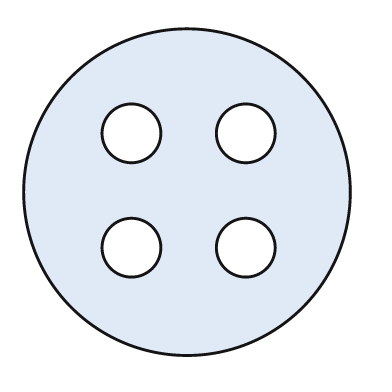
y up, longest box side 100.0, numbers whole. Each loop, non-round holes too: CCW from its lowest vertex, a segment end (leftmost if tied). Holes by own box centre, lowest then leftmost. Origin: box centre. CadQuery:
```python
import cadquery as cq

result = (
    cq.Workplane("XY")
    .moveTo(0.0, 0.0)
    .circle(50.0)
    .moveTo(-17.0, -17.0)
    .circle(9.0)
    .moveTo(18.0, -17.0)
    .circle(9.0)
    .moveTo(-17.0, 18.0)
    .circle(9.0)
    .moveTo(18.0, 18.0)
    .circle(9.0)
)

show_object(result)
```